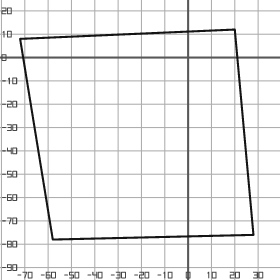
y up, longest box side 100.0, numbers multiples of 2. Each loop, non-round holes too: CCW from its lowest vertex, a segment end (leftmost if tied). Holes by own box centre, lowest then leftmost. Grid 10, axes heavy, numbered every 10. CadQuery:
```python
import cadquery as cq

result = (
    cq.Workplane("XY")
    .moveTo(-58.0, -78.0)
    .lineTo(28.0, -76.0)
    .lineTo(20.0, 12.0)
    .lineTo(-72.0, 8.0)
    .close()
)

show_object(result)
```